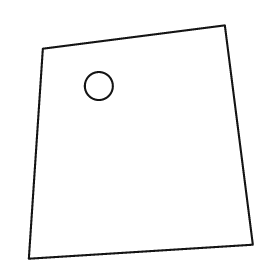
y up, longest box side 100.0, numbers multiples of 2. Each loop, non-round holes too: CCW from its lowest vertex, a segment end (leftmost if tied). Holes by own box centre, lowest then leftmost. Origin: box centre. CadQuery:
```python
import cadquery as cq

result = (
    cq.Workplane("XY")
    .moveTo(-48.0, -50.0)
    .lineTo(48.0, -44.0)
    .lineTo(36.0, 50.0)
    .lineTo(-42.0, 40.0)
    .close()
    .moveTo(-18.0, 24.0)
    .circle(6.0)
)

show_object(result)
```